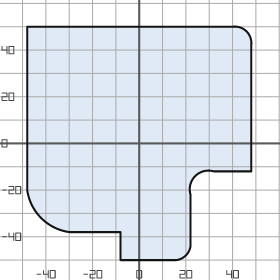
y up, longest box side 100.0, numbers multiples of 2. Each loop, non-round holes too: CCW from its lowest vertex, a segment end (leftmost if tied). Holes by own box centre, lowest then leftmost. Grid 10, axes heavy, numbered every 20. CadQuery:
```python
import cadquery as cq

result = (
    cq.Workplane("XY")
    .moveTo(-8.0, -50.0)
    .lineTo(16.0, -50.0)
    .threePointArc((20.0, -48.0), (22.0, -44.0))
    .lineTo(22.0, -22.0)
    .threePointArc((24.0, -14.0), (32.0, -12.0))
    .lineTo(48.0, -12.0)
    .lineTo(48.0, 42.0)
    .threePointArc((46.0, 48.0), (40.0, 50.0))
    .lineTo(-48.0, 50.0)
    .lineTo(-48.0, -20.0)
    .threePointArc((-42.0, -32.0), (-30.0, -38.0))
    .lineTo(-8.0, -38.0)
    .close()
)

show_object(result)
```